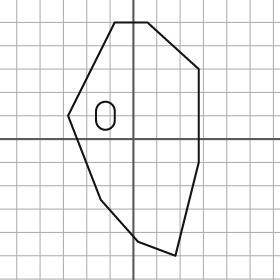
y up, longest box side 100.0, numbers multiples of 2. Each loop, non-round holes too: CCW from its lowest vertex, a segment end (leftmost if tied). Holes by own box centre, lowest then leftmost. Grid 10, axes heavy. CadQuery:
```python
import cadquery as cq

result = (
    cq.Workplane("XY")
    .moveTo(18.0, -50.0)
    .lineTo(28.0, -10.0)
    .lineTo(28.0, 30.0)
    .lineTo(6.0, 50.0)
    .lineTo(-8.0, 50.0)
    .lineTo(-28.0, 10.0)
    .lineTo(-14.0, -26.0)
    .lineTo(2.0, -44.0)
    .close()
    .moveTo(-16.0, 8.0)
    .threePointArc((-12.0, 4.0), (-8.0, 8.0))
    .lineTo(-8.0, 12.0)
    .threePointArc((-12.0, 16.0), (-16.0, 12.0))
    .close()
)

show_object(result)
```